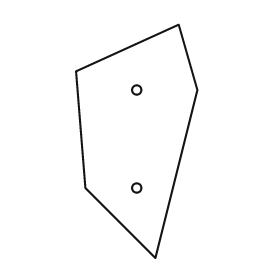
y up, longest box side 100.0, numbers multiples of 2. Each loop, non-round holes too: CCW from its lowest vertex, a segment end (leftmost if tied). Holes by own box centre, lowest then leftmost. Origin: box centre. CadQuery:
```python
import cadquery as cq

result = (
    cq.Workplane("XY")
    .moveTo(8.0, -50.0)
    .lineTo(26.0, 22.0)
    .lineTo(18.0, 50.0)
    .lineTo(-26.0, 30.0)
    .lineTo(-22.0, -20.0)
    .close()
    .moveTo(0.0, -20.0)
    .circle(2.0)
    .moveTo(0.0, 22.0)
    .circle(2.0)
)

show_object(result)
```